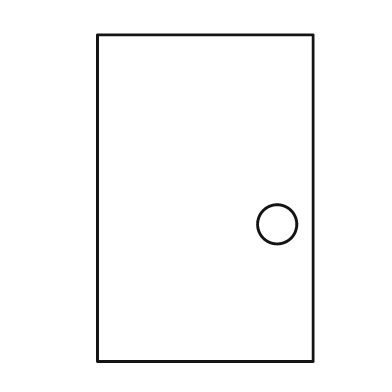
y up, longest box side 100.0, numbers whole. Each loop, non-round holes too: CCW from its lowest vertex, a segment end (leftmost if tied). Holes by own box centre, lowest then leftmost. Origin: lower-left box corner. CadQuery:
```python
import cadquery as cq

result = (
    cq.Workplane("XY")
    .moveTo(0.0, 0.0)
    .lineTo(66.0, 0.0)
    .lineTo(66.0, 100.0)
    .lineTo(0.0, 100.0)
    .close()
    .moveTo(55.0, 42.0)
    .circle(6.0)
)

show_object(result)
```